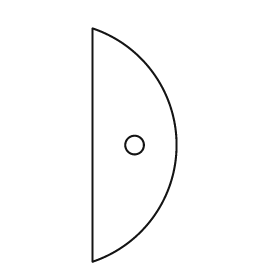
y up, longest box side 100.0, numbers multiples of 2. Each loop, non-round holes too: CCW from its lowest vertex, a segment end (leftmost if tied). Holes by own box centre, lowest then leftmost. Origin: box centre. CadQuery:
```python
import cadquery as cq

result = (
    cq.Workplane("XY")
    .moveTo(-18.0, -50.0)
    .threePointArc((18.0, 0.0), (-18.0, 50.0))
    .close()
    .moveTo(0.0, 0.0)
    .circle(4.0)
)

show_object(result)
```